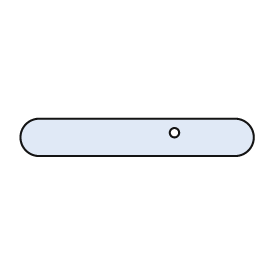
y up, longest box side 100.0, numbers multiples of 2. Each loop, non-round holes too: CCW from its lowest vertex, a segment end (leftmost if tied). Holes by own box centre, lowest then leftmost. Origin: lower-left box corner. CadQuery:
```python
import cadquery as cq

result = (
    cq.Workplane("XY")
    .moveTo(8.0, 0.0)
    .lineTo(92.0, 0.0)
    .threePointArc((100.0, 8.0), (92.0, 16.0))
    .lineTo(8.0, 16.0)
    .threePointArc((0.0, 8.0), (8.0, 0.0))
    .close()
    .moveTo(66.0, 10.0)
    .circle(2.0)
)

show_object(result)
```